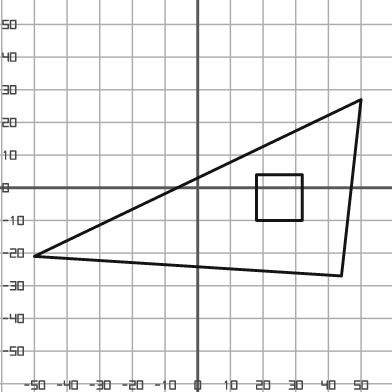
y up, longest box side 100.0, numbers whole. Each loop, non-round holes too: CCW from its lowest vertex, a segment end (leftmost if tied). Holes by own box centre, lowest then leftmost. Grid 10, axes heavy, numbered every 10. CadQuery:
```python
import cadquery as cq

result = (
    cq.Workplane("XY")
    .moveTo(44.0, -27.0)
    .lineTo(50.0, 27.0)
    .lineTo(-50.0, -21.0)
    .close()
    .moveTo(18.0, -10.0)
    .lineTo(32.0, -10.0)
    .lineTo(32.0, 4.0)
    .lineTo(18.0, 4.0)
    .close()
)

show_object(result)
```